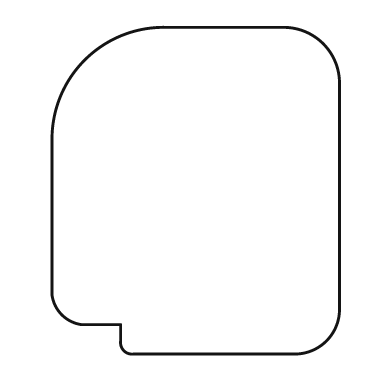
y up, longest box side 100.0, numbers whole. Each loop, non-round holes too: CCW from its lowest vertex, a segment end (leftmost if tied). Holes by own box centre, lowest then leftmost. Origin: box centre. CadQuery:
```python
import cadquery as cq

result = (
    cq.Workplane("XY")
    .moveTo(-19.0, -50.0)
    .lineTo(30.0, -50.0)
    .threePointArc((40.0, -46.0), (44.0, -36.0))
    .lineTo(44.0, 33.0)
    .threePointArc((39.0, 45.0), (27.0, 50.0))
    .lineTo(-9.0, 50.0)
    .threePointArc((-34.0, 40.0), (-44.0, 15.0))
    .lineTo(-44.0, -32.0)
    .threePointArc((-41.0, -38.0), (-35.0, -41.0))
    .lineTo(-23.0, -41.0)
    .lineTo(-23.0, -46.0)
    .threePointArc((-22.0, -49.0), (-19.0, -50.0))
    .close()
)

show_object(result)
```